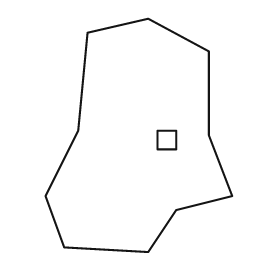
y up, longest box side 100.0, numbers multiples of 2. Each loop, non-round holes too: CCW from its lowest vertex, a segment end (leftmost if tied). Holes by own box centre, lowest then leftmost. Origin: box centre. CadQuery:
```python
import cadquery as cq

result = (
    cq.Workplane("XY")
    .moveTo(4.0, -50.0)
    .lineTo(16.0, -32.0)
    .lineTo(40.0, -26.0)
    .lineTo(30.0, 0.0)
    .lineTo(30.0, 36.0)
    .lineTo(4.0, 50.0)
    .lineTo(-22.0, 44.0)
    .lineTo(-26.0, 2.0)
    .lineTo(-40.0, -26.0)
    .lineTo(-32.0, -48.0)
    .close()
    .moveTo(8.0, -6.0)
    .lineTo(16.0, -6.0)
    .lineTo(16.0, 2.0)
    .lineTo(8.0, 2.0)
    .close()
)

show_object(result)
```